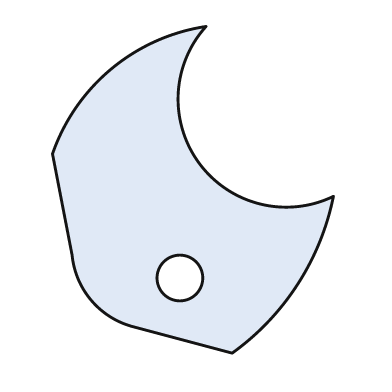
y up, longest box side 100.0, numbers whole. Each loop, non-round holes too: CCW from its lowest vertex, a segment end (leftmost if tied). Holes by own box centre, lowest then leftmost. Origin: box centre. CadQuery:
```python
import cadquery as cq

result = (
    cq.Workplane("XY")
    .moveTo(12.0, -50.0)
    .threePointArc((32.0, -29.0), (43.0, -2.0))
    .threePointArc((2.0, 8.0), (4.0, 50.0))
    .threePointArc((-25.0, 37.0), (-43.0, 11.0))
    .lineTo(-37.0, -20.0)
    .threePointArc((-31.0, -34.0), (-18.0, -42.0))
    .close()
    .moveTo(-4.0, -27.0)
    .circle(7.0)
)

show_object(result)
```